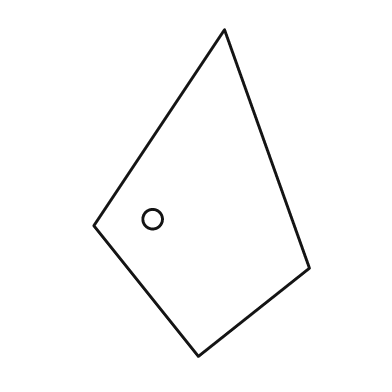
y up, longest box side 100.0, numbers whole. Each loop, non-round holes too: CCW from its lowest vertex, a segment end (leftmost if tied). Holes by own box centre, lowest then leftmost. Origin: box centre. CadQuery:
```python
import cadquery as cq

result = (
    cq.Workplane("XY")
    .moveTo(-1.0, -50.0)
    .lineTo(33.0, -23.0)
    .lineTo(7.0, 50.0)
    .lineTo(-33.0, -10.0)
    .close()
    .moveTo(-15.0, -8.0)
    .circle(3.0)
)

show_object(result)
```